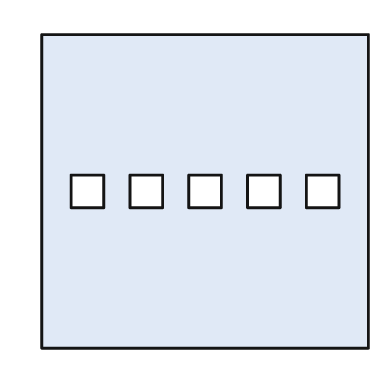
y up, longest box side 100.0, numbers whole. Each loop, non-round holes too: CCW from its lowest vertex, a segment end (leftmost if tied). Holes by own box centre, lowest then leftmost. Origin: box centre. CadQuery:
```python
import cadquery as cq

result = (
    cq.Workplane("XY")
    .moveTo(-50.0, -48.0)
    .lineTo(50.0, -48.0)
    .lineTo(50.0, 48.0)
    .lineTo(-50.0, 48.0)
    .close()
    .moveTo(-41.0, -5.0)
    .lineTo(-31.0, -5.0)
    .lineTo(-31.0, 5.0)
    .lineTo(-41.0, 5.0)
    .close()
    .moveTo(-23.0, -5.0)
    .lineTo(-13.0, -5.0)
    .lineTo(-13.0, 5.0)
    .lineTo(-23.0, 5.0)
    .close()
    .moveTo(-5.0, -5.0)
    .lineTo(5.0, -5.0)
    .lineTo(5.0, 5.0)
    .lineTo(-5.0, 5.0)
    .close()
    .moveTo(13.0, -5.0)
    .lineTo(23.0, -5.0)
    .lineTo(23.0, 5.0)
    .lineTo(13.0, 5.0)
    .close()
    .moveTo(31.0, -5.0)
    .lineTo(41.0, -5.0)
    .lineTo(41.0, 5.0)
    .lineTo(31.0, 5.0)
    .close()
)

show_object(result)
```